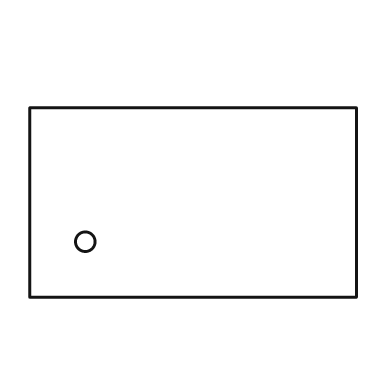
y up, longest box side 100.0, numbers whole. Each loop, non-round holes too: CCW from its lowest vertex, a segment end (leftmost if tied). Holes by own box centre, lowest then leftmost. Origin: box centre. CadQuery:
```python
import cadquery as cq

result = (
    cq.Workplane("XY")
    .moveTo(-50.0, -29.0)
    .lineTo(50.0, -29.0)
    .lineTo(50.0, 29.0)
    .lineTo(-50.0, 29.0)
    .close()
    .moveTo(-33.0, -12.0)
    .circle(3.0)
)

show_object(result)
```